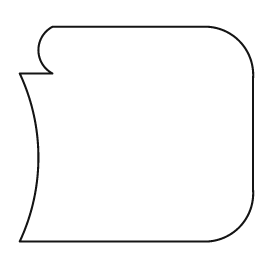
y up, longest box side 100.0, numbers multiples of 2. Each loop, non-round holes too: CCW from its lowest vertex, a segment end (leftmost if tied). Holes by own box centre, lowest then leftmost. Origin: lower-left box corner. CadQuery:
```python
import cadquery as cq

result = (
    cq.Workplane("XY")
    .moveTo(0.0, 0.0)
    .lineTo(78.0, 0.0)
    .threePointArc((94.0, 6.0), (100.0, 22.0))
    .lineTo(100.0, 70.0)
    .threePointArc((94.0, 86.0), (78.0, 92.0))
    .lineTo(14.0, 92.0)
    .threePointArc((8.0, 82.0), (14.0, 72.0))
    .lineTo(0.0, 72.0)
    .threePointArc((8.0, 36.0), (0.0, 0.0))
    .close()
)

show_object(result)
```